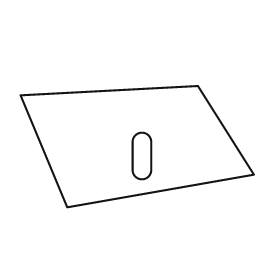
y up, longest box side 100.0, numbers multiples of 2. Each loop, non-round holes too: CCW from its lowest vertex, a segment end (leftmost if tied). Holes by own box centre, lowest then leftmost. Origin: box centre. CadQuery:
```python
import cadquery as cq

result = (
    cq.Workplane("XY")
    .moveTo(-30.0, -26.0)
    .lineTo(50.0, -12.0)
    .lineTo(26.0, 26.0)
    .lineTo(-50.0, 22.0)
    .close()
    .moveTo(-2.0, -10.0)
    .threePointArc((2.0, -14.0), (6.0, -10.0))
    .lineTo(6.0, 2.0)
    .threePointArc((2.0, 6.0), (-2.0, 2.0))
    .close()
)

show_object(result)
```